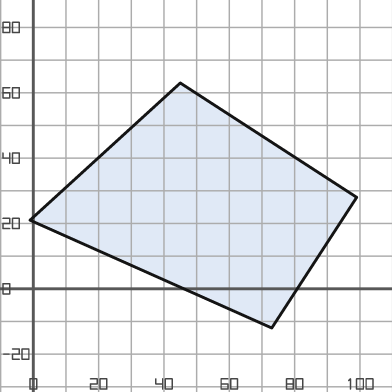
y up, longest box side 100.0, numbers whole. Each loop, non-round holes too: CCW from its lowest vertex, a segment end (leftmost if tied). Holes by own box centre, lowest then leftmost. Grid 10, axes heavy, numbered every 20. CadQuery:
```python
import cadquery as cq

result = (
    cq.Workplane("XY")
    .moveTo(73.0, -12.0)
    .lineTo(99.0, 28.0)
    .lineTo(45.0, 63.0)
    .lineTo(-1.0, 21.0)
    .close()
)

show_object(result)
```